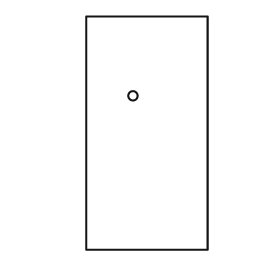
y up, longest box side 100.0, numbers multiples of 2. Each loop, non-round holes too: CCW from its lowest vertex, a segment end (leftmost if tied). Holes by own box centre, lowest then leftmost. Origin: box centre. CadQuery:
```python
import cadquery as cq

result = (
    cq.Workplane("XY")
    .moveTo(-26.0, -50.0)
    .lineTo(26.0, -50.0)
    .lineTo(26.0, 50.0)
    .lineTo(-26.0, 50.0)
    .close()
    .moveTo(-6.0, 16.0)
    .circle(2.0)
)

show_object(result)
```